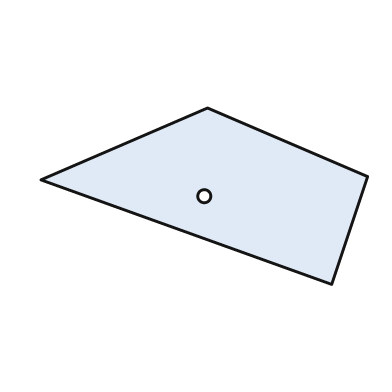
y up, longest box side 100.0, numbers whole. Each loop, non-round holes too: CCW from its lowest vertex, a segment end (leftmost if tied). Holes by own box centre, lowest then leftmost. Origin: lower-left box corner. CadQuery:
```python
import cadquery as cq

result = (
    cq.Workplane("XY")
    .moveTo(89.0, 0.0)
    .lineTo(100.0, 33.0)
    .lineTo(51.0, 54.0)
    .lineTo(0.0, 32.0)
    .close()
    .moveTo(50.0, 27.0)
    .circle(2.0)
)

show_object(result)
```